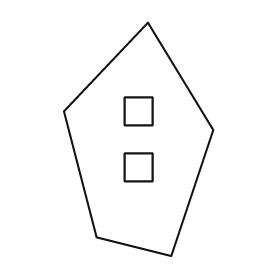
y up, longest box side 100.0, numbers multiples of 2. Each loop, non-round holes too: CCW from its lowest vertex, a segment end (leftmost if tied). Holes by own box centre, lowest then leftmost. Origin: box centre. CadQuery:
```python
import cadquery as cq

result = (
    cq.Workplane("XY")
    .moveTo(14.0, -50.0)
    .lineTo(32.0, 4.0)
    .lineTo(4.0, 50.0)
    .lineTo(-32.0, 12.0)
    .lineTo(-18.0, -42.0)
    .close()
    .moveTo(-6.0, -18.0)
    .lineTo(6.0, -18.0)
    .lineTo(6.0, -6.0)
    .lineTo(-6.0, -6.0)
    .close()
    .moveTo(-6.0, 6.0)
    .lineTo(6.0, 6.0)
    .lineTo(6.0, 18.0)
    .lineTo(-6.0, 18.0)
    .close()
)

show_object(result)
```